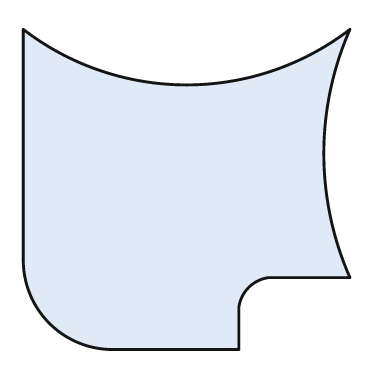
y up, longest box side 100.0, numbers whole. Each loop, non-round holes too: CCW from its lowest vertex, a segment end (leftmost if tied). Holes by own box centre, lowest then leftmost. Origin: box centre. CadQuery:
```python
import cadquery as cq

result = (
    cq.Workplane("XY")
    .moveTo(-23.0, -49.0)
    .lineTo(16.0, -49.0)
    .lineTo(16.0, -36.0)
    .threePointArc((19.0, -30.0), (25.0, -27.0))
    .lineTo(50.0, -27.0)
    .threePointArc((42.0, 11.0), (50.0, 49.0))
    .threePointArc((0.0, 32.0), (-50.0, 49.0))
    .lineTo(-50.0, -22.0)
    .threePointArc((-42.0, -41.0), (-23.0, -49.0))
    .close()
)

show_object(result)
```